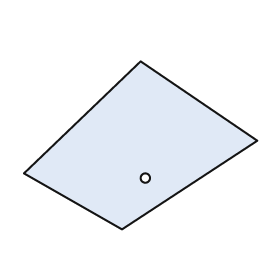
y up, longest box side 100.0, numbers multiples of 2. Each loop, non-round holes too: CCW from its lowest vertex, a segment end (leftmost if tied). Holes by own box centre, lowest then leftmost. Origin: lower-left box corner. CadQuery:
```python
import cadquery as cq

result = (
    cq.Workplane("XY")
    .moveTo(42.0, 0.0)
    .lineTo(100.0, 38.0)
    .lineTo(50.0, 72.0)
    .lineTo(0.0, 24.0)
    .close()
    .moveTo(52.0, 22.0)
    .circle(2.0)
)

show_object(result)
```